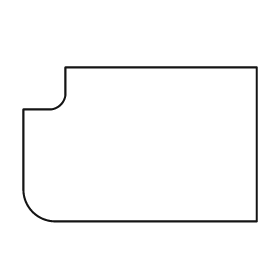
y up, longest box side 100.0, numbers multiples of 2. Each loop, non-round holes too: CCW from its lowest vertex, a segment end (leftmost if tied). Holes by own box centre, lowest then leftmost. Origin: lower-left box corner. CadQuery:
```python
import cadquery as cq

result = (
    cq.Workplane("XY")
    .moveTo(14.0, 0.0)
    .lineTo(100.0, 0.0)
    .lineTo(100.0, 66.0)
    .lineTo(18.0, 66.0)
    .lineTo(18.0, 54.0)
    .threePointArc((16.0, 50.0), (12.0, 48.0))
    .lineTo(0.0, 48.0)
    .lineTo(0.0, 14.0)
    .threePointArc((4.0, 4.0), (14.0, 0.0))
    .close()
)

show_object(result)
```